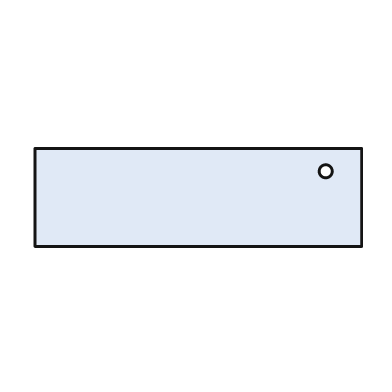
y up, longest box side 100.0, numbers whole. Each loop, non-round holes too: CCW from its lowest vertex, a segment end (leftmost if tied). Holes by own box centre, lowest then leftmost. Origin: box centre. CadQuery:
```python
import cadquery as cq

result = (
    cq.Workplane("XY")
    .moveTo(-50.0, -15.0)
    .lineTo(50.0, -15.0)
    .lineTo(50.0, 15.0)
    .lineTo(-50.0, 15.0)
    .close()
    .moveTo(39.0, 8.0)
    .circle(2.0)
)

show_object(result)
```